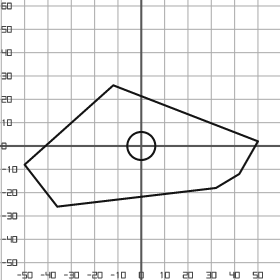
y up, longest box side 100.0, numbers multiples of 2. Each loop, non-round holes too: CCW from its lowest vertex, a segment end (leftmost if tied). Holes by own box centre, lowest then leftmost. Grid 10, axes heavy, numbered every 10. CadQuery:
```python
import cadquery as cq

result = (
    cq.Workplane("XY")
    .moveTo(-36.0, -26.0)
    .lineTo(32.0, -18.0)
    .lineTo(42.0, -12.0)
    .lineTo(50.0, 2.0)
    .lineTo(-12.0, 26.0)
    .lineTo(-50.0, -8.0)
    .close()
    .moveTo(0.0, 0.0)
    .circle(6.0)
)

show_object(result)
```